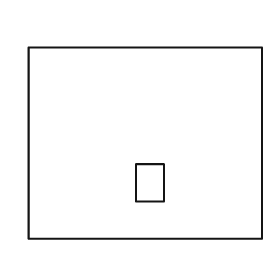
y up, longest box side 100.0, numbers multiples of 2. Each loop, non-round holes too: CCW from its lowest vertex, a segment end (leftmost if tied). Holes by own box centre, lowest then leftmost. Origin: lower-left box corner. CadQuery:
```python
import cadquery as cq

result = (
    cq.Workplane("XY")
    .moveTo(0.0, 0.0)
    .lineTo(100.0, 0.0)
    .lineTo(100.0, 82.0)
    .lineTo(0.0, 82.0)
    .close()
    .moveTo(46.0, 16.0)
    .lineTo(58.0, 16.0)
    .lineTo(58.0, 32.0)
    .lineTo(46.0, 32.0)
    .close()
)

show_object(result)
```